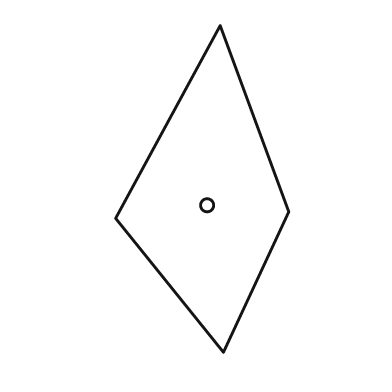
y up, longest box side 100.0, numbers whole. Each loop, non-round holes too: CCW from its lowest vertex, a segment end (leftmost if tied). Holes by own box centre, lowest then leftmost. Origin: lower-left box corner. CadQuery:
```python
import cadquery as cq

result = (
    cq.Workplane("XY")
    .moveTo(33.0, 0.0)
    .lineTo(53.0, 43.0)
    .lineTo(32.0, 100.0)
    .lineTo(0.0, 41.0)
    .close()
    .moveTo(28.0, 45.0)
    .circle(2.0)
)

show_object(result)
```